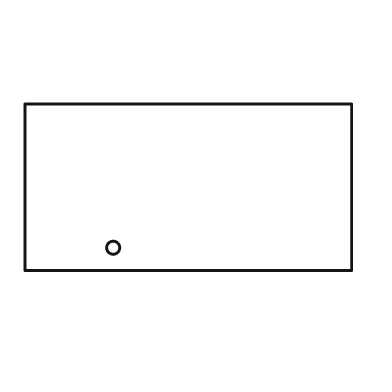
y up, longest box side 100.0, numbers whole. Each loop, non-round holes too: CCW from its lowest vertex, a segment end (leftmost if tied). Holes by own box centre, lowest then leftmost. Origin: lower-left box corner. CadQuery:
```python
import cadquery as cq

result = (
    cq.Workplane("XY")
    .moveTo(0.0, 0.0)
    .lineTo(100.0, 0.0)
    .lineTo(100.0, 51.0)
    .lineTo(0.0, 51.0)
    .close()
    .moveTo(27.0, 7.0)
    .circle(2.0)
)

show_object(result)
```